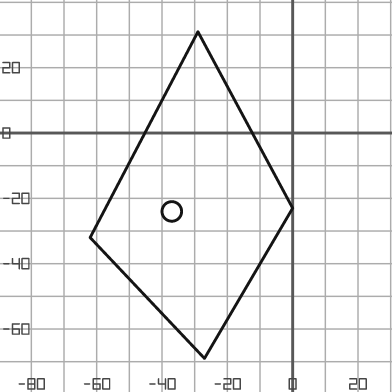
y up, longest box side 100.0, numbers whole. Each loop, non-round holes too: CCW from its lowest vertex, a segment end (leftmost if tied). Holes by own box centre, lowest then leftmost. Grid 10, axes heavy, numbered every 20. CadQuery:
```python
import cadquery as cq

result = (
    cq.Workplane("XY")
    .moveTo(-27.0, -69.0)
    .lineTo(0.0, -23.0)
    .lineTo(-29.0, 31.0)
    .lineTo(-62.0, -32.0)
    .close()
    .moveTo(-37.0, -24.0)
    .circle(3.0)
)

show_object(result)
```